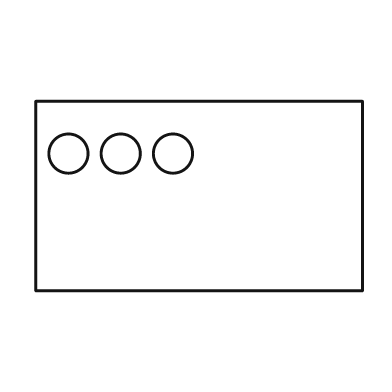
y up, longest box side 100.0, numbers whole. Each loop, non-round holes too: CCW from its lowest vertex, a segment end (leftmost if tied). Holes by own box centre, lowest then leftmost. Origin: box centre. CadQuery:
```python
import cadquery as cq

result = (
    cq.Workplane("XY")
    .moveTo(-50.0, -29.0)
    .lineTo(50.0, -29.0)
    .lineTo(50.0, 29.0)
    .lineTo(-50.0, 29.0)
    .close()
    .moveTo(-40.0, 13.0)
    .circle(6.0)
    .moveTo(-24.0, 13.0)
    .circle(6.0)
    .moveTo(-8.0, 13.0)
    .circle(6.0)
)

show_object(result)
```